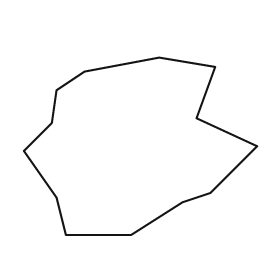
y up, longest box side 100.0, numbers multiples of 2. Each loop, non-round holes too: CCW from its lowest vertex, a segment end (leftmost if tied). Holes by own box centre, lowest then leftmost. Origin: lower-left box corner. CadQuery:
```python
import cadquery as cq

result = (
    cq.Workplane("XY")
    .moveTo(18.0, 0.0)
    .lineTo(46.0, 0.0)
    .lineTo(68.0, 14.0)
    .lineTo(80.0, 18.0)
    .lineTo(100.0, 38.0)
    .lineTo(74.0, 50.0)
    .lineTo(82.0, 72.0)
    .lineTo(58.0, 76.0)
    .lineTo(26.0, 70.0)
    .lineTo(14.0, 62.0)
    .lineTo(12.0, 48.0)
    .lineTo(0.0, 36.0)
    .lineTo(14.0, 16.0)
    .close()
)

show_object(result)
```